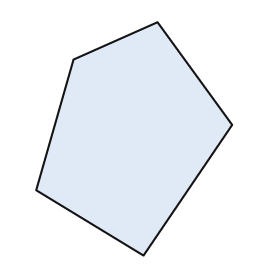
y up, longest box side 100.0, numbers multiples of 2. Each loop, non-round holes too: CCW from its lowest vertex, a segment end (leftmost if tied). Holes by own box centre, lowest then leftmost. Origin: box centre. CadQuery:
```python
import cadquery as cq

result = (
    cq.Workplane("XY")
    .moveTo(4.0, -50.0)
    .lineTo(42.0, 6.0)
    .lineTo(10.0, 50.0)
    .lineTo(-26.0, 34.0)
    .lineTo(-42.0, -22.0)
    .close()
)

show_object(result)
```